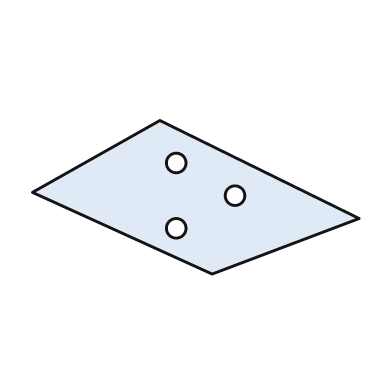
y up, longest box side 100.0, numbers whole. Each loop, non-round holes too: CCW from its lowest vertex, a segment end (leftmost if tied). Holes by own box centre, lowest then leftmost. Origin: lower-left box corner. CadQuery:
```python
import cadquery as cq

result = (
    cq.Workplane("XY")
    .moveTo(55.0, 0.0)
    .lineTo(100.0, 17.0)
    .lineTo(39.0, 47.0)
    .lineTo(0.0, 25.0)
    .close()
    .moveTo(44.0, 14.0)
    .circle(3.0)
    .moveTo(62.0, 24.0)
    .circle(3.0)
    .moveTo(44.0, 34.0)
    .circle(3.0)
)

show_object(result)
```